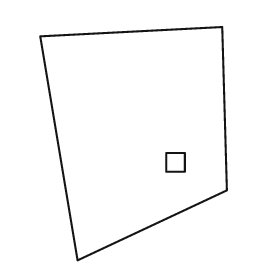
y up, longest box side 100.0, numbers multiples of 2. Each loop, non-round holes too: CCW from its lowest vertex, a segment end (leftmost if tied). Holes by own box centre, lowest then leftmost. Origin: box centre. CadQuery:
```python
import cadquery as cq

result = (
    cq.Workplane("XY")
    .moveTo(-24.0, -50.0)
    .lineTo(40.0, -20.0)
    .lineTo(38.0, 50.0)
    .lineTo(-40.0, 46.0)
    .close()
    .moveTo(14.0, -12.0)
    .lineTo(22.0, -12.0)
    .lineTo(22.0, -4.0)
    .lineTo(14.0, -4.0)
    .close()
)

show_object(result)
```